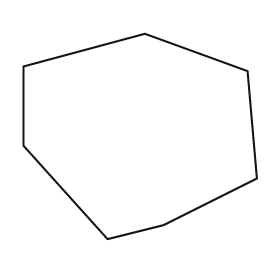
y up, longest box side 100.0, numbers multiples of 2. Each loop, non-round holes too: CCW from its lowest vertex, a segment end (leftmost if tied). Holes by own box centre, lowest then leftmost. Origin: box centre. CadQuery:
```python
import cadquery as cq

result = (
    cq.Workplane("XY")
    .moveTo(-14.0, -44.0)
    .lineTo(10.0, -38.0)
    .lineTo(50.0, -18.0)
    .lineTo(46.0, 28.0)
    .lineTo(2.0, 44.0)
    .lineTo(-50.0, 30.0)
    .lineTo(-50.0, -4.0)
    .close()
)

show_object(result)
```